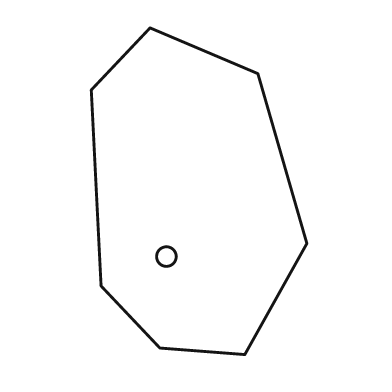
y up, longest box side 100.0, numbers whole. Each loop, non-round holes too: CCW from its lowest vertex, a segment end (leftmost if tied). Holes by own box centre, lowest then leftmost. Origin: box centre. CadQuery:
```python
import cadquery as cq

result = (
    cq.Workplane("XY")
    .moveTo(14.0, -50.0)
    .lineTo(33.0, -16.0)
    .lineTo(18.0, 36.0)
    .lineTo(-15.0, 50.0)
    .lineTo(-33.0, 31.0)
    .lineTo(-30.0, -29.0)
    .lineTo(-12.0, -48.0)
    .close()
    .moveTo(-10.0, -20.0)
    .circle(3.0)
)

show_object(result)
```